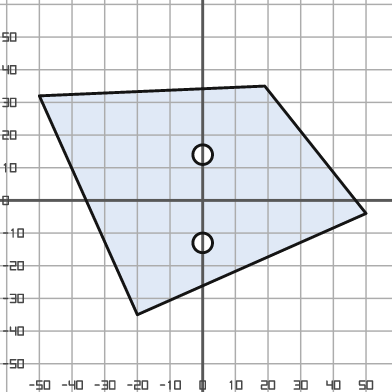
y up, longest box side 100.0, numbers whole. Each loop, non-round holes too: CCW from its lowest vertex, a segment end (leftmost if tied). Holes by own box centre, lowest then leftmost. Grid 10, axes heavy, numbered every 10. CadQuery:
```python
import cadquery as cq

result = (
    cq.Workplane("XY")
    .moveTo(-20.0, -35.0)
    .lineTo(50.0, -4.0)
    .lineTo(19.0, 35.0)
    .lineTo(-50.0, 32.0)
    .close()
    .moveTo(0.0, -13.0)
    .circle(3.0)
    .moveTo(0.0, 14.0)
    .circle(3.0)
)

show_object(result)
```